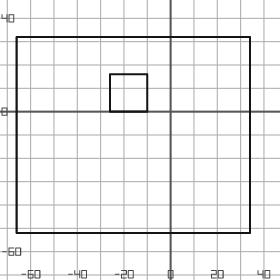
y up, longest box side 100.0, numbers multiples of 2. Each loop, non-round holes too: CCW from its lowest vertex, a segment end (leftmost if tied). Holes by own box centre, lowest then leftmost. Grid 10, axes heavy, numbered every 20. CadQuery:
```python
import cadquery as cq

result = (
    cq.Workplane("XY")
    .moveTo(-66.0, -52.0)
    .lineTo(34.0, -52.0)
    .lineTo(34.0, 32.0)
    .lineTo(-66.0, 32.0)
    .close()
    .moveTo(-26.0, 0.0)
    .lineTo(-10.0, 0.0)
    .lineTo(-10.0, 16.0)
    .lineTo(-26.0, 16.0)
    .close()
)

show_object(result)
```